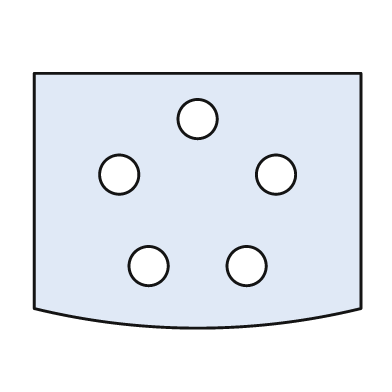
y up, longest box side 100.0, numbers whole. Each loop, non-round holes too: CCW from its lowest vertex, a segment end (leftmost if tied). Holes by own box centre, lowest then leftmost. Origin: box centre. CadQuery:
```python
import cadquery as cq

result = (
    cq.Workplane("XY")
    .moveTo(-50.0, -33.0)
    .threePointArc((0.0, -39.0), (50.0, -33.0))
    .lineTo(50.0, 39.0)
    .lineTo(-50.0, 39.0)
    .close()
    .moveTo(-15.0, -20.0)
    .circle(6.0)
    .moveTo(15.0, -20.0)
    .circle(6.0)
    .moveTo(-24.0, 8.0)
    .circle(6.0)
    .moveTo(24.0, 8.0)
    .circle(6.0)
    .moveTo(0.0, 25.0)
    .circle(6.0)
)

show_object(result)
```